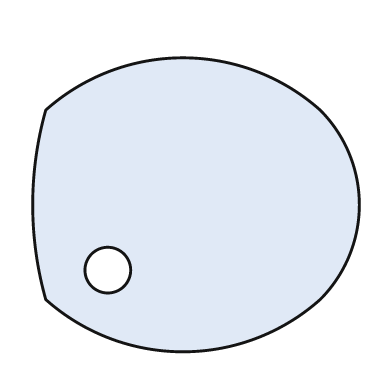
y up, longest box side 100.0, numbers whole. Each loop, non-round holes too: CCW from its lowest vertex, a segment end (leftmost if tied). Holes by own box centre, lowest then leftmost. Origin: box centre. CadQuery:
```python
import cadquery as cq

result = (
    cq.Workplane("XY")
    .moveTo(-46.0, -29.0)
    .threePointArc((-4.0, -45.0), (38.0, -29.0))
    .threePointArc((50.0, 0.0), (38.0, 29.0))
    .threePointArc((-4.0, 45.0), (-46.0, 29.0))
    .threePointArc((-50.0, 0.0), (-46.0, -29.0))
    .close()
    .moveTo(-27.0, -20.0)
    .circle(7.0)
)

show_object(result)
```